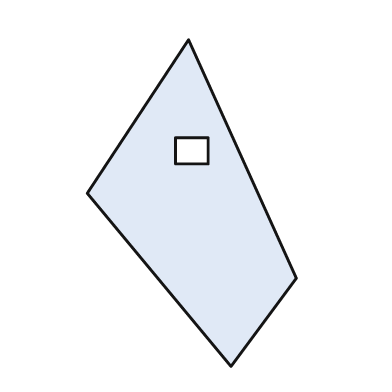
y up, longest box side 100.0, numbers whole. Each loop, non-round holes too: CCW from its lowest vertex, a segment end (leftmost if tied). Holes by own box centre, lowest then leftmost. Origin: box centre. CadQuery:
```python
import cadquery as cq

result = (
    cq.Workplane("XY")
    .moveTo(12.0, -50.0)
    .lineTo(32.0, -23.0)
    .lineTo(-1.0, 50.0)
    .lineTo(-32.0, 3.0)
    .close()
    .moveTo(-5.0, 12.0)
    .lineTo(5.0, 12.0)
    .lineTo(5.0, 20.0)
    .lineTo(-5.0, 20.0)
    .close()
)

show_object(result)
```